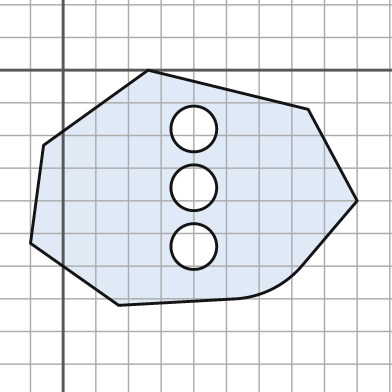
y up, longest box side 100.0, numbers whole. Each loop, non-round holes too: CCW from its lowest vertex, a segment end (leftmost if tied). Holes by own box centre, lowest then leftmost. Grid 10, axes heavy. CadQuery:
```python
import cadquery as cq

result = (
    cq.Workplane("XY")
    .moveTo(17.0, -72.0)
    .lineTo(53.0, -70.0)
    .threePointArc((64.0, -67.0), (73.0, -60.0))
    .lineTo(90.0, -40.0)
    .lineTo(75.0, -12.0)
    .lineTo(26.0, 0.0)
    .lineTo(-6.0, -23.0)
    .lineTo(-10.0, -53.0)
    .close()
    .moveTo(40.0, -54.0)
    .circle(7.0)
    .moveTo(40.0, -36.0)
    .circle(7.0)
    .moveTo(40.0, -18.0)
    .circle(7.0)
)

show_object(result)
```